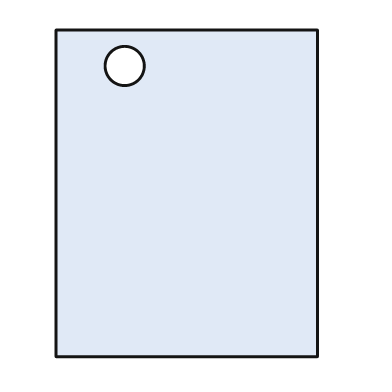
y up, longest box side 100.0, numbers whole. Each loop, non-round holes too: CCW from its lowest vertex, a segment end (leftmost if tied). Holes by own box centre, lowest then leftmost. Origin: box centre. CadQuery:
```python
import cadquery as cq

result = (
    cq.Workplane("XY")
    .moveTo(-40.0, -50.0)
    .lineTo(40.0, -50.0)
    .lineTo(40.0, 50.0)
    .lineTo(-40.0, 50.0)
    .close()
    .moveTo(-19.0, 39.0)
    .circle(6.0)
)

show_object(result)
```